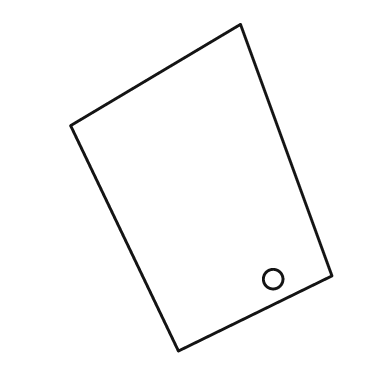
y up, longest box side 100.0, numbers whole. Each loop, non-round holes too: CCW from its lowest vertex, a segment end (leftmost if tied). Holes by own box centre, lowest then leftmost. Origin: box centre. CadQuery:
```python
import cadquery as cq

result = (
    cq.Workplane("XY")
    .moveTo(-7.0, -50.0)
    .lineTo(40.0, -27.0)
    .lineTo(12.0, 50.0)
    .lineTo(-40.0, 19.0)
    .close()
    .moveTo(22.0, -28.0)
    .circle(3.0)
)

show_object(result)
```